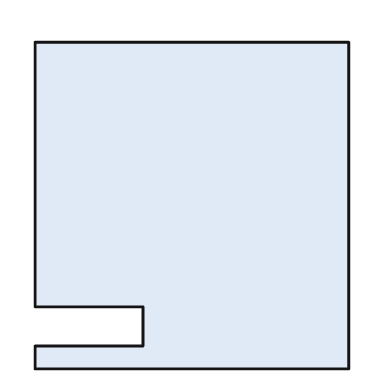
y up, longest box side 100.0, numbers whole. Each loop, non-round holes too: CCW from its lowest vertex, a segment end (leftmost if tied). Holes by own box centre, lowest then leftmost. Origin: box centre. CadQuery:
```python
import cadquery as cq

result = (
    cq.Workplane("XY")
    .moveTo(-48.0, -50.0)
    .lineTo(48.0, -50.0)
    .lineTo(48.0, 50.0)
    .lineTo(-48.0, 50.0)
    .lineTo(-48.0, -31.0)
    .lineTo(-15.0, -31.0)
    .lineTo(-15.0, -43.0)
    .lineTo(-48.0, -43.0)
    .close()
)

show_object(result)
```